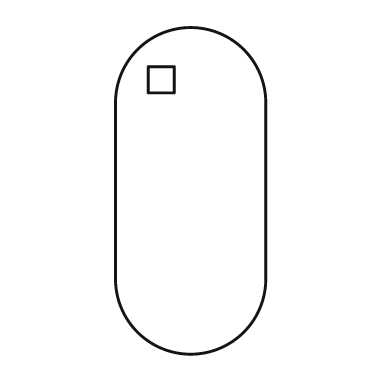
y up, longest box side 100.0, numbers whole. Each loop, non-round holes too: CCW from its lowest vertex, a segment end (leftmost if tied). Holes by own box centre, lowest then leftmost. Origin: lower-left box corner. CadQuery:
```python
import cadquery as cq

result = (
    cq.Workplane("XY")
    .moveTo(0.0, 23.0)
    .threePointArc((23.0, 0.0), (46.0, 23.0))
    .lineTo(46.0, 77.0)
    .threePointArc((23.0, 100.0), (0.0, 77.0))
    .close()
    .moveTo(10.0, 80.0)
    .lineTo(18.0, 80.0)
    .lineTo(18.0, 88.0)
    .lineTo(10.0, 88.0)
    .close()
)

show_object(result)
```